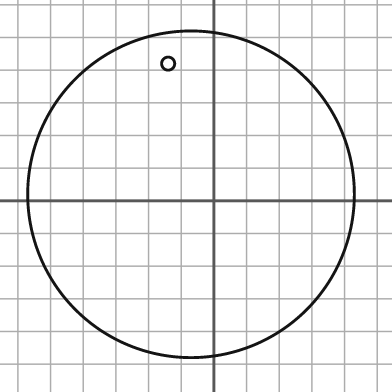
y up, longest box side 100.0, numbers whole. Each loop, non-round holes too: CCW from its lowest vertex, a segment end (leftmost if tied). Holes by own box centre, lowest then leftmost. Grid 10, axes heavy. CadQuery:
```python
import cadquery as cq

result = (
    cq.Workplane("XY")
    .moveTo(-7.0, 2.0)
    .circle(50.0)
    .moveTo(-14.0, 42.0)
    .circle(2.0)
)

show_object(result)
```